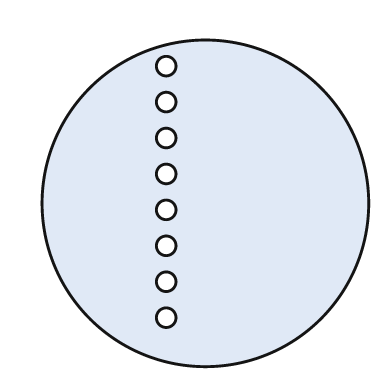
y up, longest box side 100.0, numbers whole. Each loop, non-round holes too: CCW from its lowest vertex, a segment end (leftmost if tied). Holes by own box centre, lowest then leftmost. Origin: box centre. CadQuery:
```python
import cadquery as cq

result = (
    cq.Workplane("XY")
    .moveTo(0.0, 0.0)
    .circle(50.0)
    .moveTo(-12.0, -35.0)
    .circle(3.0)
    .moveTo(-12.0, -24.0)
    .circle(3.0)
    .moveTo(-12.0, -13.0)
    .circle(3.0)
    .moveTo(-12.0, -2.0)
    .circle(3.0)
    .moveTo(-12.0, 9.0)
    .circle(3.0)
    .moveTo(-12.0, 20.0)
    .circle(3.0)
    .moveTo(-12.0, 31.0)
    .circle(3.0)
    .moveTo(-12.0, 42.0)
    .circle(3.0)
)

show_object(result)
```